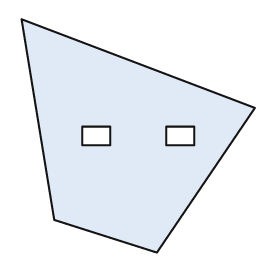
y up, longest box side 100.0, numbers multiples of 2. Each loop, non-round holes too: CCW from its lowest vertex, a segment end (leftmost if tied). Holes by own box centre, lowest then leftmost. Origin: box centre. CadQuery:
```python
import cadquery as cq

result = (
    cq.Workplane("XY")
    .moveTo(8.0, -50.0)
    .lineTo(50.0, 12.0)
    .lineTo(-50.0, 50.0)
    .lineTo(-36.0, -36.0)
    .close()
    .moveTo(-24.0, -4.0)
    .lineTo(-12.0, -4.0)
    .lineTo(-12.0, 4.0)
    .lineTo(-24.0, 4.0)
    .close()
    .moveTo(12.0, -4.0)
    .lineTo(24.0, -4.0)
    .lineTo(24.0, 4.0)
    .lineTo(12.0, 4.0)
    .close()
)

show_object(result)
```